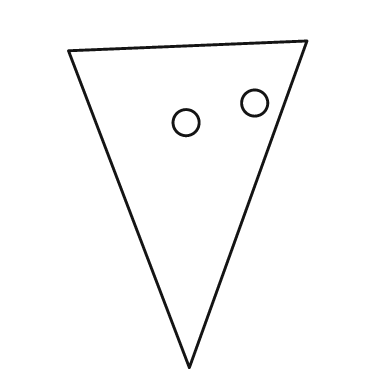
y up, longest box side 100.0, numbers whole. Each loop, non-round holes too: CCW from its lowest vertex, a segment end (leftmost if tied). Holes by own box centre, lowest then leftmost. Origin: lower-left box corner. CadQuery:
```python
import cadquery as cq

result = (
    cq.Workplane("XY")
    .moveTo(37.0, 0.0)
    .lineTo(73.0, 100.0)
    .lineTo(0.0, 97.0)
    .close()
    .moveTo(36.0, 75.0)
    .circle(4.0)
    .moveTo(57.0, 81.0)
    .circle(4.0)
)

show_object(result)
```